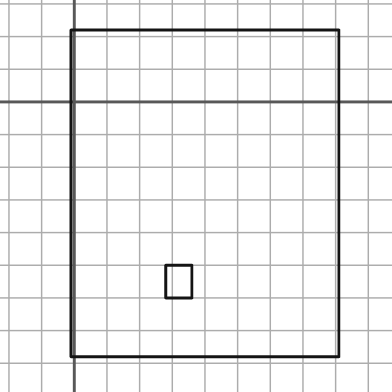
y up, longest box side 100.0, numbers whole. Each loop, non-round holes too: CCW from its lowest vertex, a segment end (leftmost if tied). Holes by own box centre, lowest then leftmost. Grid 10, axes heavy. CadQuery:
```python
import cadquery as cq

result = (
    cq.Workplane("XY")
    .moveTo(-1.0, -78.0)
    .lineTo(81.0, -78.0)
    .lineTo(81.0, 22.0)
    .lineTo(-1.0, 22.0)
    .close()
    .moveTo(28.0, -60.0)
    .lineTo(36.0, -60.0)
    .lineTo(36.0, -50.0)
    .lineTo(28.0, -50.0)
    .close()
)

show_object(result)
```